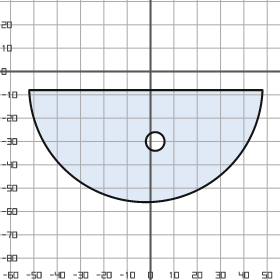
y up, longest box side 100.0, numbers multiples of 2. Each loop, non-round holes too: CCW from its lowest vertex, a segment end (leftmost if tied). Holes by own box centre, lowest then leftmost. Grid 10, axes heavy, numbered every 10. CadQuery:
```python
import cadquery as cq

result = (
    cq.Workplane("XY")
    .moveTo(-52.0, -8.0)
    .threePointArc((-2.0, -56.0), (48.0, -8.0))
    .close()
    .moveTo(2.0, -30.0)
    .circle(4.0)
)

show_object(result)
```